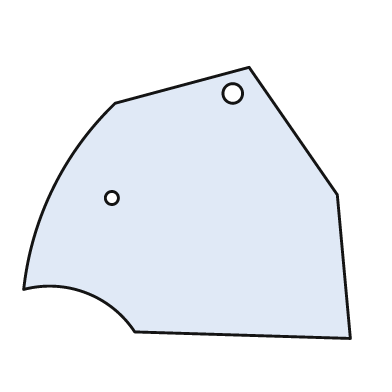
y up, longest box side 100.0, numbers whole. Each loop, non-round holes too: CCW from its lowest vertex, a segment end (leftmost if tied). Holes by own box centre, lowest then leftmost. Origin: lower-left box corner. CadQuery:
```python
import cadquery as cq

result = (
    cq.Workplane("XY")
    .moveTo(100.0, 0.0)
    .lineTo(96.0, 44.0)
    .lineTo(69.0, 83.0)
    .lineTo(28.0, 72.0)
    .threePointArc((9.0, 46.0), (0.0, 15.0))
    .threePointArc((19.0, 14.0), (34.0, 2.0))
    .close()
    .moveTo(27.0, 43.0)
    .circle(2.0)
    .moveTo(64.0, 75.0)
    .circle(3.0)
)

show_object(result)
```